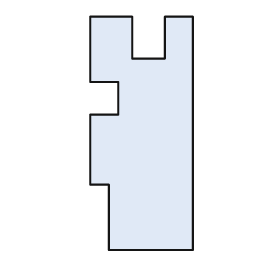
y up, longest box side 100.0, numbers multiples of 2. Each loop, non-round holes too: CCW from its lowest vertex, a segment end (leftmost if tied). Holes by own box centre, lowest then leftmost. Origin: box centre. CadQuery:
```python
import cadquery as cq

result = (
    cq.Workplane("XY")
    .moveTo(-14.0, -50.0)
    .lineTo(22.0, -50.0)
    .lineTo(22.0, 50.0)
    .lineTo(10.0, 50.0)
    .lineTo(10.0, 32.0)
    .lineTo(-4.0, 32.0)
    .lineTo(-4.0, 50.0)
    .lineTo(-22.0, 50.0)
    .lineTo(-22.0, 22.0)
    .lineTo(-10.0, 22.0)
    .lineTo(-10.0, 8.0)
    .lineTo(-22.0, 8.0)
    .lineTo(-22.0, -22.0)
    .lineTo(-14.0, -22.0)
    .close()
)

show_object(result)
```